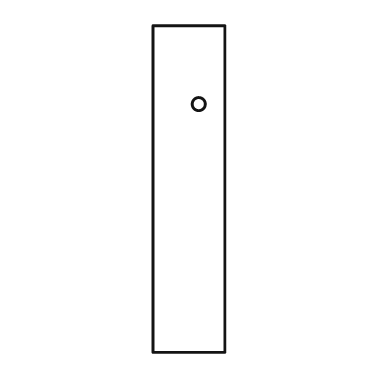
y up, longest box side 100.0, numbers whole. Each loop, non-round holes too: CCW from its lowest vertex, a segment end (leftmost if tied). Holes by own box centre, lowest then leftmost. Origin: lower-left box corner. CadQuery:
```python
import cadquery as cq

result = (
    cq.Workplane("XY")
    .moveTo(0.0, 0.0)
    .lineTo(22.0, 0.0)
    .lineTo(22.0, 100.0)
    .lineTo(0.0, 100.0)
    .close()
    .moveTo(14.0, 76.0)
    .circle(2.0)
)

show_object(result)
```